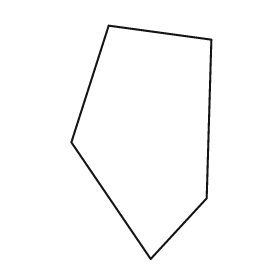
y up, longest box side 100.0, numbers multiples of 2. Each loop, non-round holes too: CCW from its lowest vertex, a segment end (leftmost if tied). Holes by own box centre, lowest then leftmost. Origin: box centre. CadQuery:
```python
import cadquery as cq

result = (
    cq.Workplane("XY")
    .moveTo(4.0, -50.0)
    .lineTo(28.0, -24.0)
    .lineTo(30.0, 44.0)
    .lineTo(-14.0, 50.0)
    .lineTo(-30.0, 0.0)
    .close()
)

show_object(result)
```